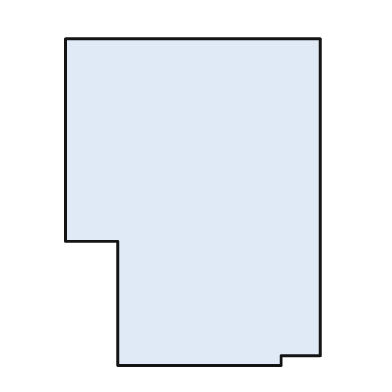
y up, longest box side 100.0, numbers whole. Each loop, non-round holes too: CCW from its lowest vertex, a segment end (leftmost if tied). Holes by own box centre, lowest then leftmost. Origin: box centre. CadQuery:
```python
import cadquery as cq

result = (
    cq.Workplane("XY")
    .moveTo(-23.0, -50.0)
    .lineTo(27.0, -50.0)
    .lineTo(27.0, -47.0)
    .lineTo(39.0, -47.0)
    .lineTo(39.0, 50.0)
    .lineTo(-39.0, 50.0)
    .lineTo(-39.0, -12.0)
    .lineTo(-23.0, -12.0)
    .close()
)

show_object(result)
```